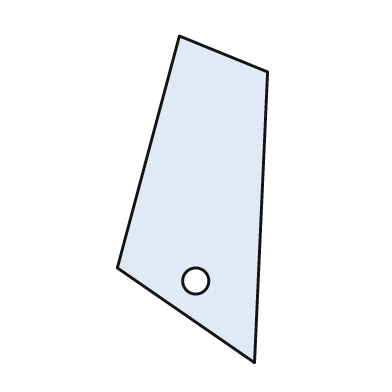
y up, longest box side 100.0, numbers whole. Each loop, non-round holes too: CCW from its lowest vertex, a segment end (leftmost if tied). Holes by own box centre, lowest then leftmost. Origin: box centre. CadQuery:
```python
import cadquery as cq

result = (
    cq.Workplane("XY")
    .moveTo(19.0, -50.0)
    .lineTo(23.0, 39.0)
    .lineTo(-4.0, 50.0)
    .lineTo(-23.0, -21.0)
    .close()
    .moveTo(1.0, -25.0)
    .circle(4.0)
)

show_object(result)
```